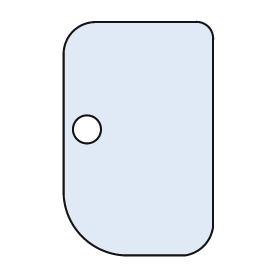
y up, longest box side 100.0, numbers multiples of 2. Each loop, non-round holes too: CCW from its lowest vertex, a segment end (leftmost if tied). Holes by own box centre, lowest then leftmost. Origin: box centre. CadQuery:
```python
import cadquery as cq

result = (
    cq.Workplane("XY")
    .moveTo(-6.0, -50.0)
    .lineTo(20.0, -50.0)
    .threePointArc((28.0, -46.0), (32.0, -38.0))
    .lineTo(32.0, 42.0)
    .threePointArc((30.0, 48.0), (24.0, 50.0))
    .lineTo(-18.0, 50.0)
    .threePointArc((-28.0, 46.0), (-32.0, 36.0))
    .lineTo(-32.0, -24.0)
    .threePointArc((-24.0, -42.0), (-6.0, -50.0))
    .close()
    .moveTo(-22.0, 4.0)
    .circle(6.0)
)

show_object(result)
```